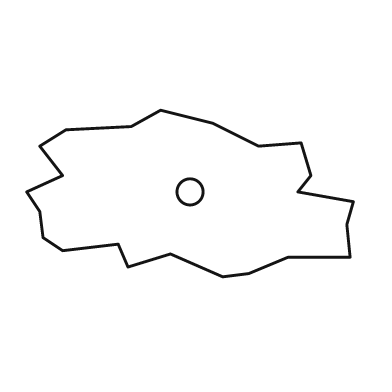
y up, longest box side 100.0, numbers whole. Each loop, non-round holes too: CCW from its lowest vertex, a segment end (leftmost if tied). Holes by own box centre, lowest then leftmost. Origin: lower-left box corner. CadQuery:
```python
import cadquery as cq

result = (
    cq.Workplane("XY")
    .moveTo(60.0, 0.0)
    .lineTo(68.0, 1.0)
    .lineTo(80.0, 6.0)
    .lineTo(99.0, 6.0)
    .lineTo(98.0, 16.0)
    .lineTo(100.0, 23.0)
    .lineTo(83.0, 26.0)
    .lineTo(87.0, 31.0)
    .lineTo(84.0, 41.0)
    .lineTo(71.0, 40.0)
    .lineTo(57.0, 47.0)
    .lineTo(41.0, 51.0)
    .lineTo(32.0, 46.0)
    .lineTo(12.0, 45.0)
    .lineTo(4.0, 40.0)
    .lineTo(11.0, 31.0)
    .lineTo(0.0, 26.0)
    .lineTo(4.0, 20.0)
    .lineTo(5.0, 12.0)
    .lineTo(11.0, 8.0)
    .lineTo(28.0, 10.0)
    .lineTo(31.0, 3.0)
    .lineTo(44.0, 7.0)
    .close()
    .moveTo(50.0, 26.0)
    .circle(4.0)
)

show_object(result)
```